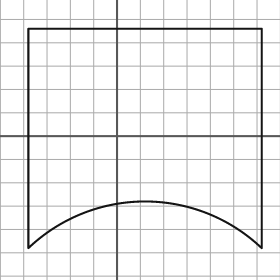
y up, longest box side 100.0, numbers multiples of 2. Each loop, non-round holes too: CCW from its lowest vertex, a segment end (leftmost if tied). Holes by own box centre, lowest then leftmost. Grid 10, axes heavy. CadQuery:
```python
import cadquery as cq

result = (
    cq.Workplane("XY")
    .moveTo(-38.0, -48.0)
    .threePointArc((12.0, -28.0), (62.0, -48.0))
    .lineTo(62.0, 46.0)
    .lineTo(-38.0, 46.0)
    .close()
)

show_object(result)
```